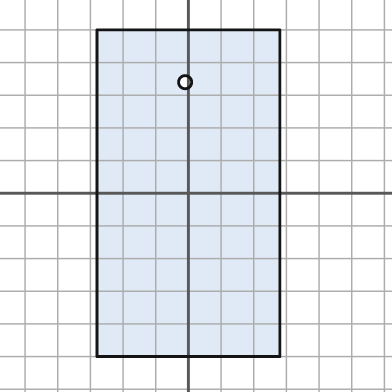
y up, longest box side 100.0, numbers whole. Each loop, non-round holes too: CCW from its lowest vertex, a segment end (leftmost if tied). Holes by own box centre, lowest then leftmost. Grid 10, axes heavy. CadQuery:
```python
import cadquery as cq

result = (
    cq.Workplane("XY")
    .moveTo(-28.0, -50.0)
    .lineTo(28.0, -50.0)
    .lineTo(28.0, 50.0)
    .lineTo(-28.0, 50.0)
    .close()
    .moveTo(-1.0, 34.0)
    .circle(2.0)
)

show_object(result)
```